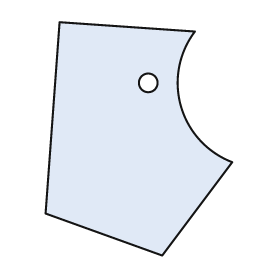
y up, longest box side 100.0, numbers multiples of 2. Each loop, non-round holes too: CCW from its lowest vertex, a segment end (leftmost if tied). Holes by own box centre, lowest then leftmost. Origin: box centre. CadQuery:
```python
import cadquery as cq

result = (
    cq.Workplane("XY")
    .moveTo(10.0, -50.0)
    .lineTo(40.0, -10.0)
    .threePointArc((18.0, 14.0), (24.0, 46.0))
    .lineTo(-34.0, 50.0)
    .lineTo(-40.0, -32.0)
    .close()
    .moveTo(4.0, 24.0)
    .circle(4.0)
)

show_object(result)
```